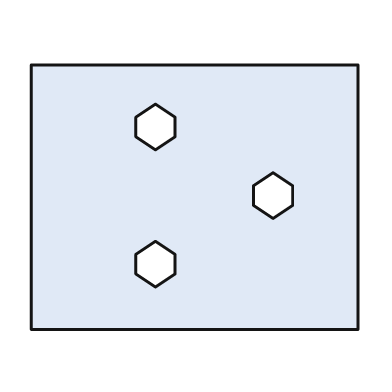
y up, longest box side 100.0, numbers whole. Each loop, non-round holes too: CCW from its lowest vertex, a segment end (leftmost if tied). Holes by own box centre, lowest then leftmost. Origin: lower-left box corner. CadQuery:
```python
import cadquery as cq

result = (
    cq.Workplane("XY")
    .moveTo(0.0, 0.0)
    .lineTo(100.0, 0.0)
    .lineTo(100.0, 81.0)
    .lineTo(0.0, 81.0)
    .close()
    .moveTo(38.0, 13.0)
    .lineTo(44.0, 17.0)
    .lineTo(44.0, 23.0)
    .lineTo(38.0, 27.0)
    .lineTo(32.0, 23.0)
    .lineTo(32.0, 17.0)
    .close()
    .moveTo(74.0, 34.0)
    .lineTo(80.0, 38.0)
    .lineTo(80.0, 44.0)
    .lineTo(74.0, 48.0)
    .lineTo(68.0, 44.0)
    .lineTo(68.0, 38.0)
    .close()
    .moveTo(38.0, 55.0)
    .lineTo(44.0, 59.0)
    .lineTo(44.0, 65.0)
    .lineTo(38.0, 69.0)
    .lineTo(32.0, 65.0)
    .lineTo(32.0, 59.0)
    .close()
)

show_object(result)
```